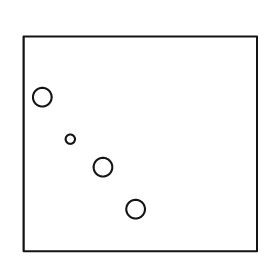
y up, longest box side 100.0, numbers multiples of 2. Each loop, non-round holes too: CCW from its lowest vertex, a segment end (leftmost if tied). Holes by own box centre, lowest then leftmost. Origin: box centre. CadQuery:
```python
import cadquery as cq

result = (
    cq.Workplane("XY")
    .moveTo(-50.0, -46.0)
    .lineTo(50.0, -46.0)
    .lineTo(50.0, 46.0)
    .lineTo(-50.0, 46.0)
    .close()
    .moveTo(-2.0, -28.0)
    .circle(4.0)
    .moveTo(-16.0, -10.0)
    .circle(4.0)
    .moveTo(-30.0, 2.0)
    .circle(2.0)
    .moveTo(-42.0, 20.0)
    .circle(4.0)
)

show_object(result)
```